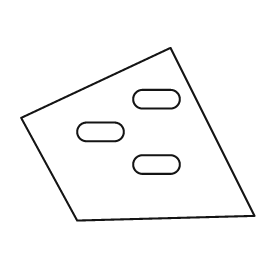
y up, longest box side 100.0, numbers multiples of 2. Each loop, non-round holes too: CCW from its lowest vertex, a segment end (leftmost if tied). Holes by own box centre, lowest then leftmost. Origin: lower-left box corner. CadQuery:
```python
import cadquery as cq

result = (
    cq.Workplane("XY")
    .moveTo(24.0, 0.0)
    .lineTo(100.0, 2.0)
    .lineTo(64.0, 74.0)
    .lineTo(0.0, 44.0)
    .close()
    .moveTo(52.0, 20.0)
    .lineTo(64.0, 20.0)
    .threePointArc((68.0, 24.0), (64.0, 28.0))
    .lineTo(52.0, 28.0)
    .threePointArc((48.0, 24.0), (52.0, 20.0))
    .close()
    .moveTo(28.0, 34.0)
    .lineTo(40.0, 34.0)
    .threePointArc((44.0, 38.0), (40.0, 42.0))
    .lineTo(28.0, 42.0)
    .threePointArc((24.0, 38.0), (28.0, 34.0))
    .close()
    .moveTo(52.0, 48.0)
    .lineTo(64.0, 48.0)
    .threePointArc((68.0, 52.0), (64.0, 56.0))
    .lineTo(52.0, 56.0)
    .threePointArc((48.0, 52.0), (52.0, 48.0))
    .close()
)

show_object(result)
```